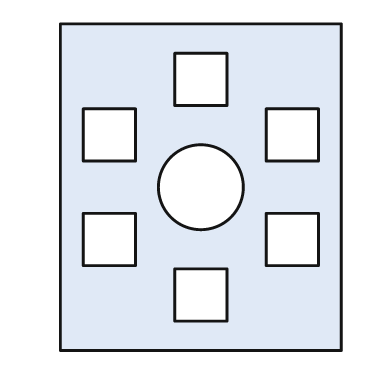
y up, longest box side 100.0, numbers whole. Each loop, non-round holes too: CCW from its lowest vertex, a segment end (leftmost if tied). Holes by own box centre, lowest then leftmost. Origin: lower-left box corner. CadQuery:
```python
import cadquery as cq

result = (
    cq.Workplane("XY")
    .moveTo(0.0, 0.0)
    .lineTo(86.0, 0.0)
    .lineTo(86.0, 100.0)
    .lineTo(0.0, 100.0)
    .close()
    .moveTo(35.0, 9.0)
    .lineTo(51.0, 9.0)
    .lineTo(51.0, 25.0)
    .lineTo(35.0, 25.0)
    .close()
    .moveTo(7.0, 26.0)
    .lineTo(23.0, 26.0)
    .lineTo(23.0, 42.0)
    .lineTo(7.0, 42.0)
    .close()
    .moveTo(63.0, 26.0)
    .lineTo(79.0, 26.0)
    .lineTo(79.0, 42.0)
    .lineTo(63.0, 42.0)
    .close()
    .moveTo(43.0, 50.0)
    .circle(13.0)
    .moveTo(7.0, 58.0)
    .lineTo(23.0, 58.0)
    .lineTo(23.0, 74.0)
    .lineTo(7.0, 74.0)
    .close()
    .moveTo(63.0, 58.0)
    .lineTo(79.0, 58.0)
    .lineTo(79.0, 74.0)
    .lineTo(63.0, 74.0)
    .close()
    .moveTo(35.0, 75.0)
    .lineTo(51.0, 75.0)
    .lineTo(51.0, 91.0)
    .lineTo(35.0, 91.0)
    .close()
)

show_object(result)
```